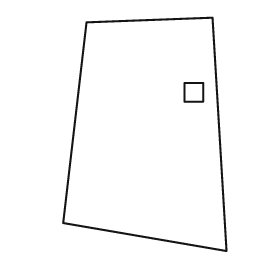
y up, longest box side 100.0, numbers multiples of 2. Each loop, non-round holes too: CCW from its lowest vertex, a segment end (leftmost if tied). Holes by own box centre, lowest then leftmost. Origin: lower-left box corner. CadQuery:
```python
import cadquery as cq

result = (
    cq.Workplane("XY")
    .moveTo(70.0, 0.0)
    .lineTo(64.0, 100.0)
    .lineTo(10.0, 98.0)
    .lineTo(0.0, 12.0)
    .close()
    .moveTo(52.0, 64.0)
    .lineTo(60.0, 64.0)
    .lineTo(60.0, 72.0)
    .lineTo(52.0, 72.0)
    .close()
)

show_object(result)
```